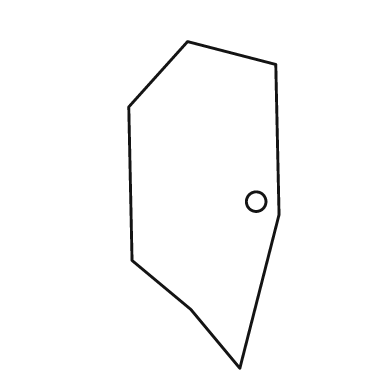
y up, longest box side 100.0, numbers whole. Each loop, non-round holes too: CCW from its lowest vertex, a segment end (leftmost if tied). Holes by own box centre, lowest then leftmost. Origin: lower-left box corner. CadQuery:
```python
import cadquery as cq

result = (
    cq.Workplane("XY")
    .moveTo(34.0, 0.0)
    .lineTo(46.0, 47.0)
    .lineTo(45.0, 93.0)
    .lineTo(18.0, 100.0)
    .lineTo(0.0, 80.0)
    .lineTo(1.0, 33.0)
    .lineTo(19.0, 18.0)
    .close()
    .moveTo(39.0, 51.0)
    .circle(3.0)
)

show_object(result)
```